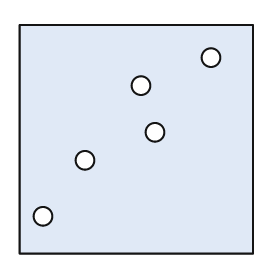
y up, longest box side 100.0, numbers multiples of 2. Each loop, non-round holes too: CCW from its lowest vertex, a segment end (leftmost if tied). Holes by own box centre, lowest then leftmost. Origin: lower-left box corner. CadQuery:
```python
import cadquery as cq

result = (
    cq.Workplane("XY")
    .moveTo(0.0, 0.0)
    .lineTo(100.0, 0.0)
    .lineTo(100.0, 98.0)
    .lineTo(0.0, 98.0)
    .close()
    .moveTo(10.0, 16.0)
    .circle(4.0)
    .moveTo(28.0, 40.0)
    .circle(4.0)
    .moveTo(58.0, 52.0)
    .circle(4.0)
    .moveTo(52.0, 72.0)
    .circle(4.0)
    .moveTo(82.0, 84.0)
    .circle(4.0)
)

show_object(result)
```